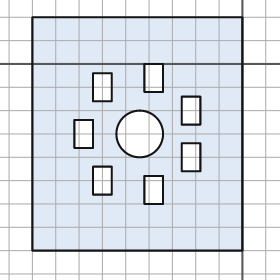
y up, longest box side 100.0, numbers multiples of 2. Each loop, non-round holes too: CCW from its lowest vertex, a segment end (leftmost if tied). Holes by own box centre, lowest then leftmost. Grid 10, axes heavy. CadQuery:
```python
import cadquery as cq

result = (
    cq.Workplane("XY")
    .moveTo(-90.0, -80.0)
    .lineTo(0.0, -80.0)
    .lineTo(0.0, 20.0)
    .lineTo(-90.0, 20.0)
    .close()
    .moveTo(-42.0, -60.0)
    .lineTo(-34.0, -60.0)
    .lineTo(-34.0, -48.0)
    .lineTo(-42.0, -48.0)
    .close()
    .moveTo(-64.0, -56.0)
    .lineTo(-56.0, -56.0)
    .lineTo(-56.0, -44.0)
    .lineTo(-64.0, -44.0)
    .close()
    .moveTo(-26.0, -46.0)
    .lineTo(-18.0, -46.0)
    .lineTo(-18.0, -34.0)
    .lineTo(-26.0, -34.0)
    .close()
    .moveTo(-72.0, -36.0)
    .lineTo(-64.0, -36.0)
    .lineTo(-64.0, -24.0)
    .lineTo(-72.0, -24.0)
    .close()
    .moveTo(-44.0, -30.0)
    .circle(10.0)
    .moveTo(-26.0, -26.0)
    .lineTo(-18.0, -26.0)
    .lineTo(-18.0, -14.0)
    .lineTo(-26.0, -14.0)
    .close()
    .moveTo(-64.0, -16.0)
    .lineTo(-56.0, -16.0)
    .lineTo(-56.0, -4.0)
    .lineTo(-64.0, -4.0)
    .close()
    .moveTo(-42.0, -12.0)
    .lineTo(-34.0, -12.0)
    .lineTo(-34.0, 0.0)
    .lineTo(-42.0, 0.0)
    .close()
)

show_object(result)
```